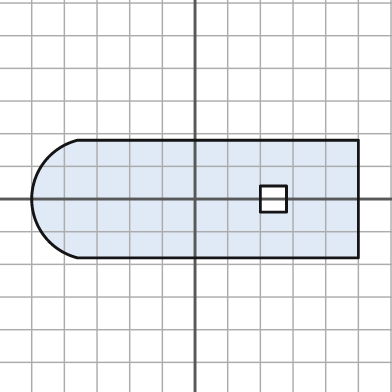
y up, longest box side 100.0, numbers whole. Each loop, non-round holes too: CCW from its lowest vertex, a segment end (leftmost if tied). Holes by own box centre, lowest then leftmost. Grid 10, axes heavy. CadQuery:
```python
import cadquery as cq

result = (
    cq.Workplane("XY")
    .moveTo(-36.0, -18.0)
    .lineTo(50.0, -18.0)
    .lineTo(50.0, 18.0)
    .lineTo(-36.0, 18.0)
    .threePointArc((-50.0, 0.0), (-36.0, -18.0))
    .close()
    .moveTo(20.0, -4.0)
    .lineTo(28.0, -4.0)
    .lineTo(28.0, 4.0)
    .lineTo(20.0, 4.0)
    .close()
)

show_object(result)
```